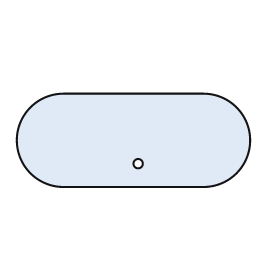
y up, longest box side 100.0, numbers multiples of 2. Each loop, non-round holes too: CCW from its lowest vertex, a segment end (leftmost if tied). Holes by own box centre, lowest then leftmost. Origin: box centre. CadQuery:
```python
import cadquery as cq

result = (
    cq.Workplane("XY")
    .moveTo(-30.0, -20.0)
    .lineTo(30.0, -20.0)
    .threePointArc((50.0, 0.0), (30.0, 20.0))
    .lineTo(-30.0, 20.0)
    .threePointArc((-50.0, 0.0), (-30.0, -20.0))
    .close()
    .moveTo(2.0, -10.0)
    .circle(2.0)
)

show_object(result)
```